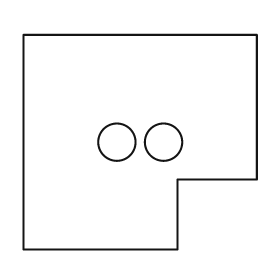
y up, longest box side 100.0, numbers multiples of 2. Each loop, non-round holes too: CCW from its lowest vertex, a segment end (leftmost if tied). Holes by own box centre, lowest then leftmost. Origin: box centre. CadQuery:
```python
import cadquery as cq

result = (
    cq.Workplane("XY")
    .moveTo(-50.0, -46.0)
    .lineTo(16.0, -46.0)
    .lineTo(16.0, -16.0)
    .lineTo(50.0, -16.0)
    .lineTo(50.0, 46.0)
    .lineTo(-50.0, 46.0)
    .close()
    .moveTo(-10.0, 0.0)
    .circle(8.0)
    .moveTo(10.0, 0.0)
    .circle(8.0)
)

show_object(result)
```